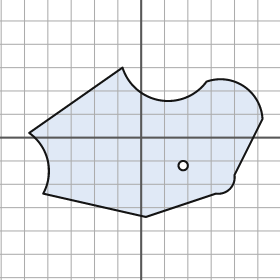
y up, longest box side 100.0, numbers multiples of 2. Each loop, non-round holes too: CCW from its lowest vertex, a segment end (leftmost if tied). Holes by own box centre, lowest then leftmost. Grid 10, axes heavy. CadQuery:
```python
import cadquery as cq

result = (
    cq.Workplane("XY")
    .moveTo(2.0, -34.0)
    .lineTo(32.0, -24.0)
    .threePointArc((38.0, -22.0), (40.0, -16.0))
    .lineTo(52.0, 8.0)
    .threePointArc((44.0, 22.0), (28.0, 24.0))
    .threePointArc((8.0, 16.0), (-8.0, 30.0))
    .lineTo(-48.0, 2.0)
    .threePointArc((-40.0, -10.0), (-42.0, -24.0))
    .close()
    .moveTo(18.0, -12.0)
    .circle(2.0)
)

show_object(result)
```